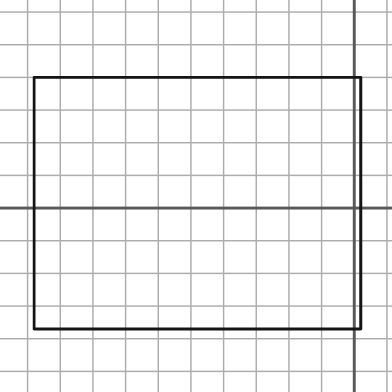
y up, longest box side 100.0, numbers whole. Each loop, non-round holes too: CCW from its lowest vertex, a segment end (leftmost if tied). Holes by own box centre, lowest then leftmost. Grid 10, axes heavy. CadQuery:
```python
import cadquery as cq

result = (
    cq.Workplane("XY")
    .moveTo(-98.0, -37.0)
    .lineTo(2.0, -37.0)
    .lineTo(2.0, 40.0)
    .lineTo(-98.0, 40.0)
    .close()
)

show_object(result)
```